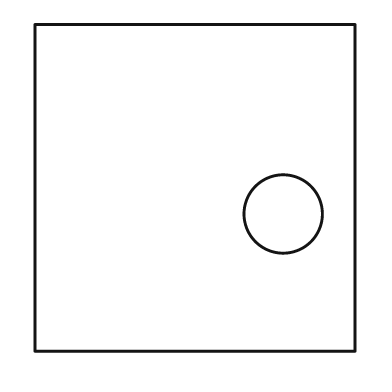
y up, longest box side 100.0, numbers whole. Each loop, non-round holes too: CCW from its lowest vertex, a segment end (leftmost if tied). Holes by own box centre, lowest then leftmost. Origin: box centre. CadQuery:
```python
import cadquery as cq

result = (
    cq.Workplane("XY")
    .moveTo(-49.0, -50.0)
    .lineTo(49.0, -50.0)
    .lineTo(49.0, 50.0)
    .lineTo(-49.0, 50.0)
    .close()
    .moveTo(27.0, -8.0)
    .circle(12.0)
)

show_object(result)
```